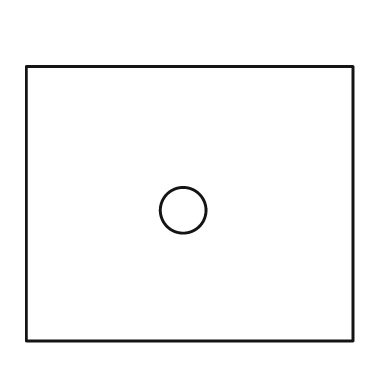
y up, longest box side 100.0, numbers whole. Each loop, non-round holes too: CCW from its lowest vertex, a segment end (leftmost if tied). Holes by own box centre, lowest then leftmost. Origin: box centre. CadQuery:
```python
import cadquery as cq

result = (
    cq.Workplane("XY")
    .moveTo(-50.0, -42.0)
    .lineTo(50.0, -42.0)
    .lineTo(50.0, 42.0)
    .lineTo(-50.0, 42.0)
    .close()
    .moveTo(-2.0, -2.0)
    .circle(7.0)
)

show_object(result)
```